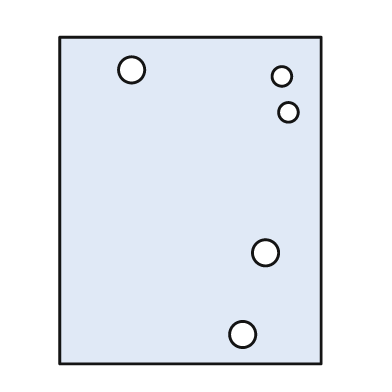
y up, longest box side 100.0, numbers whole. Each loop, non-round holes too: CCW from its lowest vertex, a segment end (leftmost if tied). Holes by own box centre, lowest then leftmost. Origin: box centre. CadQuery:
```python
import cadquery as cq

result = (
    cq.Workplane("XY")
    .moveTo(-40.0, -50.0)
    .lineTo(40.0, -50.0)
    .lineTo(40.0, 50.0)
    .lineTo(-40.0, 50.0)
    .close()
    .moveTo(16.0, -41.0)
    .circle(4.0)
    .moveTo(23.0, -16.0)
    .circle(4.0)
    .moveTo(30.0, 27.0)
    .circle(3.0)
    .moveTo(28.0, 38.0)
    .circle(3.0)
    .moveTo(-18.0, 40.0)
    .circle(4.0)
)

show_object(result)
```